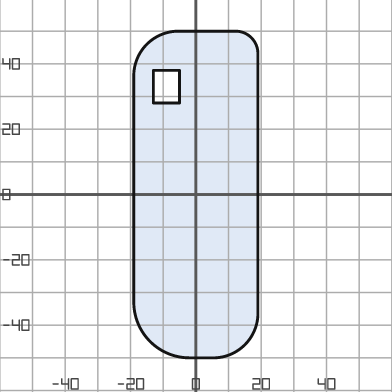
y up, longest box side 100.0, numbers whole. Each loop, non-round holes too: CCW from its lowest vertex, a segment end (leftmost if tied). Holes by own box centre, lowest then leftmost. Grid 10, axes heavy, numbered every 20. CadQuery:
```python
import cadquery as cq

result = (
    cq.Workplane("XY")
    .moveTo(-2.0, -50.0)
    .lineTo(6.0, -50.0)
    .threePointArc((15.0, -46.0), (19.0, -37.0))
    .lineTo(19.0, 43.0)
    .threePointArc((17.0, 48.0), (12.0, 50.0))
    .lineTo(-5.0, 50.0)
    .threePointArc((-15.0, 46.0), (-19.0, 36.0))
    .lineTo(-19.0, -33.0)
    .threePointArc((-14.0, -45.0), (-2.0, -50.0))
    .close()
    .moveTo(-13.0, 28.0)
    .lineTo(-5.0, 28.0)
    .lineTo(-5.0, 38.0)
    .lineTo(-13.0, 38.0)
    .close()
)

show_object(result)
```